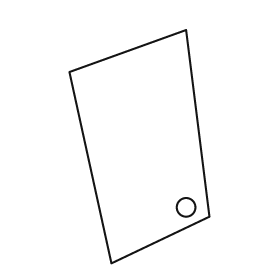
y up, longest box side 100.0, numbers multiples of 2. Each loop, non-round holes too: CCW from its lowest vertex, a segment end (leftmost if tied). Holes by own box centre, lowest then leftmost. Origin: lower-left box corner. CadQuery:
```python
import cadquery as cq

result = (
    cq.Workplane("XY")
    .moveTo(18.0, 0.0)
    .lineTo(60.0, 20.0)
    .lineTo(50.0, 100.0)
    .lineTo(0.0, 82.0)
    .close()
    .moveTo(50.0, 24.0)
    .circle(4.0)
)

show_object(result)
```